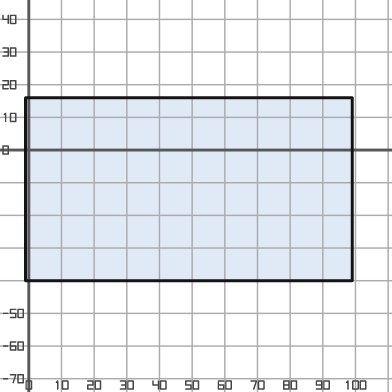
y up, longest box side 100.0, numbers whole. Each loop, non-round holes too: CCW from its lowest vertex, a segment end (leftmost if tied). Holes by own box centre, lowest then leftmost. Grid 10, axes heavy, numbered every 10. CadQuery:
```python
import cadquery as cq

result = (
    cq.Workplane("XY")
    .moveTo(-1.0, -40.0)
    .lineTo(99.0, -40.0)
    .lineTo(99.0, 16.0)
    .lineTo(-1.0, 16.0)
    .close()
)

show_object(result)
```